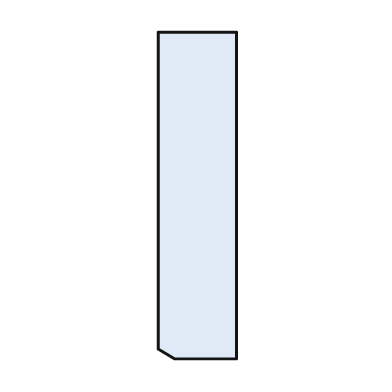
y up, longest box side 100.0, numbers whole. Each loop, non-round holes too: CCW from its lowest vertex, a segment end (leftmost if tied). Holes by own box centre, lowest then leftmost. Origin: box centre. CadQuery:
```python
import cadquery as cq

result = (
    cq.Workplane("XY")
    .moveTo(-7.0, -50.0)
    .lineTo(12.0, -50.0)
    .lineTo(12.0, 50.0)
    .lineTo(-12.0, 50.0)
    .lineTo(-12.0, -47.0)
    .close()
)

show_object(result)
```